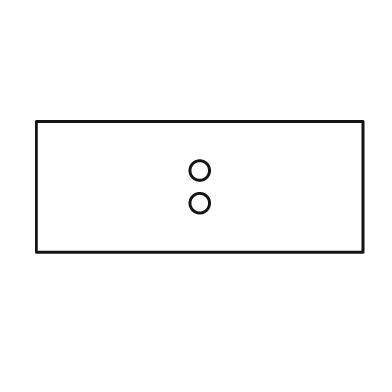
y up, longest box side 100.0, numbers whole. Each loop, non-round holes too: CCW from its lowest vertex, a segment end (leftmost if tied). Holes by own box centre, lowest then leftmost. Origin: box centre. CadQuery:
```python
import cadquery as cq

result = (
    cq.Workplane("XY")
    .moveTo(-50.0, -20.0)
    .lineTo(50.0, -20.0)
    .lineTo(50.0, 20.0)
    .lineTo(-50.0, 20.0)
    .close()
    .moveTo(0.0, -5.0)
    .circle(3.0)
    .moveTo(0.0, 5.0)
    .circle(3.0)
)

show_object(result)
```